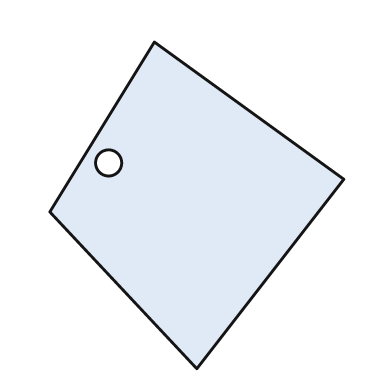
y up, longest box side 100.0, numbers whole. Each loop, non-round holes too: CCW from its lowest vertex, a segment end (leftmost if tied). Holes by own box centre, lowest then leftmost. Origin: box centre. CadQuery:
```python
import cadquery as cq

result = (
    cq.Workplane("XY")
    .moveTo(0.0, -50.0)
    .lineTo(45.0, 8.0)
    .lineTo(-13.0, 50.0)
    .lineTo(-45.0, -2.0)
    .close()
    .moveTo(-27.0, 13.0)
    .circle(4.0)
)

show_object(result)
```